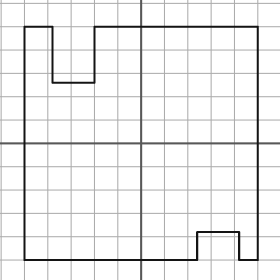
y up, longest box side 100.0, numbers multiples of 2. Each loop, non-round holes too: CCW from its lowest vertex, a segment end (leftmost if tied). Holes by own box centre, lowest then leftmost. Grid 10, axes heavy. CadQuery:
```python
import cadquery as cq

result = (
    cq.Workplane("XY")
    .moveTo(-50.0, -50.0)
    .lineTo(24.0, -50.0)
    .lineTo(24.0, -38.0)
    .lineTo(42.0, -38.0)
    .lineTo(42.0, -50.0)
    .lineTo(50.0, -50.0)
    .lineTo(50.0, 50.0)
    .lineTo(-20.0, 50.0)
    .lineTo(-20.0, 26.0)
    .lineTo(-38.0, 26.0)
    .lineTo(-38.0, 50.0)
    .lineTo(-50.0, 50.0)
    .close()
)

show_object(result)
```